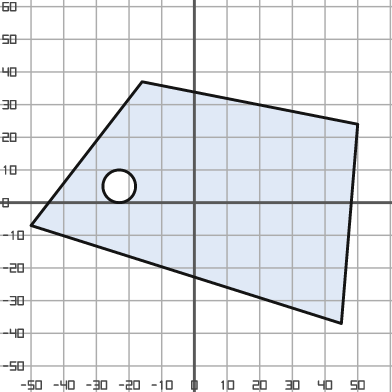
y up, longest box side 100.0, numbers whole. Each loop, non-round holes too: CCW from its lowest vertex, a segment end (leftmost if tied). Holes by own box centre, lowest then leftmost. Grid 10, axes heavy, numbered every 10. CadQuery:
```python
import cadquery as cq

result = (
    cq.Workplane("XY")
    .moveTo(45.0, -37.0)
    .lineTo(50.0, 24.0)
    .lineTo(-16.0, 37.0)
    .lineTo(-50.0, -7.0)
    .close()
    .moveTo(-23.0, 5.0)
    .circle(5.0)
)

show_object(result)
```